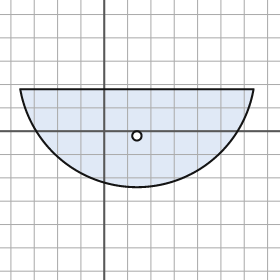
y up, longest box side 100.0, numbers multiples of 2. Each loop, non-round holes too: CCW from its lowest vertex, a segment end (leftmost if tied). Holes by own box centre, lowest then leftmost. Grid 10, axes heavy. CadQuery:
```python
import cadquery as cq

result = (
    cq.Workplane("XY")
    .moveTo(-36.0, 18.0)
    .threePointArc((14.0, -24.0), (64.0, 18.0))
    .close()
    .moveTo(14.0, -2.0)
    .circle(2.0)
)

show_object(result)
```